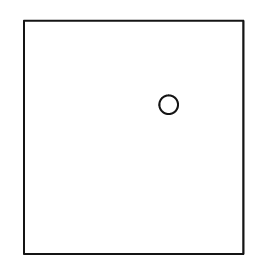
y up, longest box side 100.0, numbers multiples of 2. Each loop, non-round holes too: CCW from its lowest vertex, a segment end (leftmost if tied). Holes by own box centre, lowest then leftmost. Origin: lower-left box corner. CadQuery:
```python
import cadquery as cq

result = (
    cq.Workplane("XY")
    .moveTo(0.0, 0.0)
    .lineTo(94.0, 0.0)
    .lineTo(94.0, 100.0)
    .lineTo(0.0, 100.0)
    .close()
    .moveTo(62.0, 64.0)
    .circle(4.0)
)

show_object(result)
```